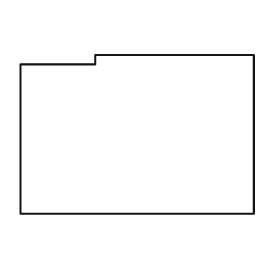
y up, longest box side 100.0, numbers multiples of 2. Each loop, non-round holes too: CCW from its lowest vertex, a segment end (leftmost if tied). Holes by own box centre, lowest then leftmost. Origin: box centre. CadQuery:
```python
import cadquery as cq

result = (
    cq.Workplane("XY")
    .moveTo(-50.0, -34.0)
    .lineTo(50.0, -34.0)
    .lineTo(50.0, 34.0)
    .lineTo(-18.0, 34.0)
    .lineTo(-18.0, 30.0)
    .lineTo(-50.0, 30.0)
    .close()
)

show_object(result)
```